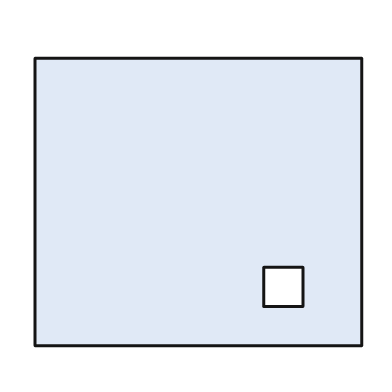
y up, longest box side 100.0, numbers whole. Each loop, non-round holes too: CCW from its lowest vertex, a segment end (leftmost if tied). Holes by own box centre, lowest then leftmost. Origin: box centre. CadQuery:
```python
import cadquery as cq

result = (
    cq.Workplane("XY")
    .moveTo(-50.0, -44.0)
    .lineTo(50.0, -44.0)
    .lineTo(50.0, 44.0)
    .lineTo(-50.0, 44.0)
    .close()
    .moveTo(20.0, -32.0)
    .lineTo(32.0, -32.0)
    .lineTo(32.0, -20.0)
    .lineTo(20.0, -20.0)
    .close()
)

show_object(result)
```